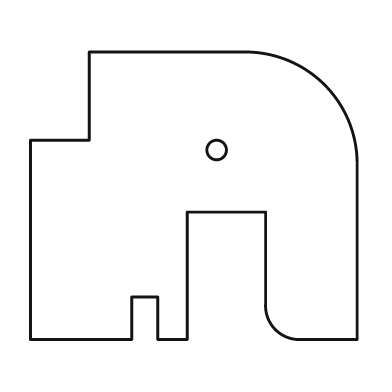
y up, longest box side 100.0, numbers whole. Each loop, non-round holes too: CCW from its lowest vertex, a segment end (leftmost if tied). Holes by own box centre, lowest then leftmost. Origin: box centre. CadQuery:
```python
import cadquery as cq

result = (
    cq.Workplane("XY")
    .moveTo(-50.0, -44.0)
    .lineTo(-19.0, -44.0)
    .lineTo(-19.0, -31.0)
    .lineTo(-11.0, -31.0)
    .lineTo(-11.0, -44.0)
    .lineTo(-2.0, -44.0)
    .lineTo(-2.0, -5.0)
    .lineTo(22.0, -5.0)
    .lineTo(22.0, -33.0)
    .threePointArc((25.0, -41.0), (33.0, -44.0))
    .lineTo(50.0, -44.0)
    .lineTo(50.0, 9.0)
    .threePointArc((40.0, 34.0), (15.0, 44.0))
    .lineTo(-32.0, 44.0)
    .lineTo(-32.0, 17.0)
    .lineTo(-50.0, 17.0)
    .close()
    .moveTo(7.0, 14.0)
    .circle(3.0)
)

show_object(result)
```